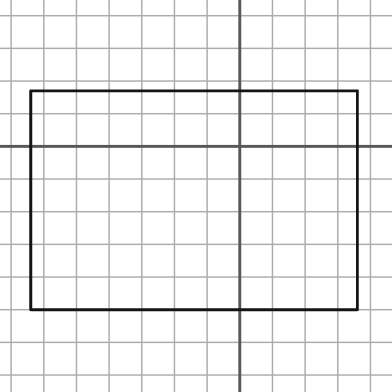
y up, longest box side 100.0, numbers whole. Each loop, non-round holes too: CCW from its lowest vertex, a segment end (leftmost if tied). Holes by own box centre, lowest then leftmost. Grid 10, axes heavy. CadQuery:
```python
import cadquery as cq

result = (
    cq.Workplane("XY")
    .moveTo(-64.0, -50.0)
    .lineTo(36.0, -50.0)
    .lineTo(36.0, 17.0)
    .lineTo(-64.0, 17.0)
    .close()
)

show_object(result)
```